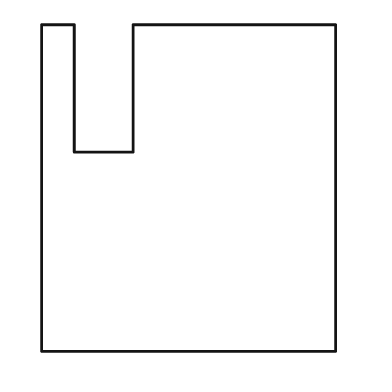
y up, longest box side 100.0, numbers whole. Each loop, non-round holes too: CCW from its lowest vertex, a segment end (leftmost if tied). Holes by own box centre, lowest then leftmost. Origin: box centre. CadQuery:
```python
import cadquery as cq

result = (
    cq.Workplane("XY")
    .moveTo(-45.0, -50.0)
    .lineTo(45.0, -50.0)
    .lineTo(45.0, 50.0)
    .lineTo(-17.0, 50.0)
    .lineTo(-17.0, 11.0)
    .lineTo(-35.0, 11.0)
    .lineTo(-35.0, 50.0)
    .lineTo(-45.0, 50.0)
    .close()
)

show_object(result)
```